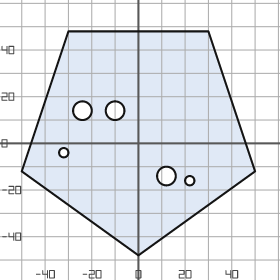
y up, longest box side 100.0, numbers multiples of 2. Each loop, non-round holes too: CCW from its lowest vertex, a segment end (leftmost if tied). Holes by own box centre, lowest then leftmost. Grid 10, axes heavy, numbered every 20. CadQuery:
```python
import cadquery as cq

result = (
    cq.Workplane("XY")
    .moveTo(0.0, -48.0)
    .lineTo(50.0, -12.0)
    .lineTo(30.0, 48.0)
    .lineTo(-30.0, 48.0)
    .lineTo(-50.0, -12.0)
    .close()
    .moveTo(22.0, -16.0)
    .circle(2.0)
    .moveTo(12.0, -14.0)
    .circle(4.0)
    .moveTo(-32.0, -4.0)
    .circle(2.0)
    .moveTo(-24.0, 14.0)
    .circle(4.0)
    .moveTo(-10.0, 14.0)
    .circle(4.0)
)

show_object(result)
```